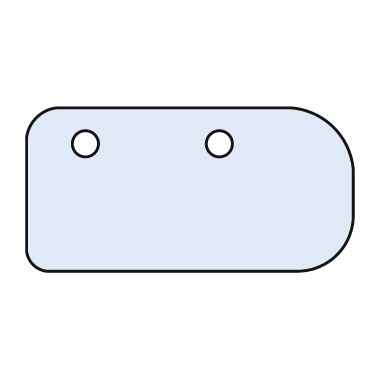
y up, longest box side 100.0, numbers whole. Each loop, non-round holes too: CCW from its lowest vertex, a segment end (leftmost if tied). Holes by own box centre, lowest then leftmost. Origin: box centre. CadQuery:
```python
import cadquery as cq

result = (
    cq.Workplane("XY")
    .moveTo(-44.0, -25.0)
    .lineTo(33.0, -25.0)
    .threePointArc((45.0, -20.0), (50.0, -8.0))
    .lineTo(50.0, 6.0)
    .threePointArc((44.0, 19.0), (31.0, 25.0))
    .lineTo(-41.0, 25.0)
    .threePointArc((-47.0, 22.0), (-50.0, 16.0))
    .lineTo(-50.0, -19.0)
    .threePointArc((-48.0, -23.0), (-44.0, -25.0))
    .close()
    .moveTo(-32.0, 14.0)
    .circle(4.0)
    .moveTo(9.0, 14.0)
    .circle(4.0)
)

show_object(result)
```